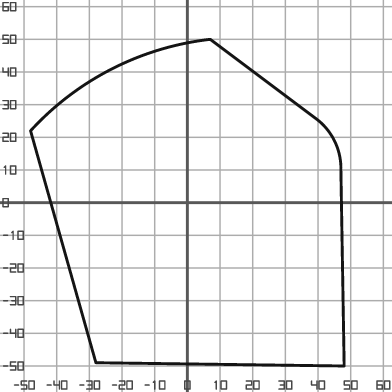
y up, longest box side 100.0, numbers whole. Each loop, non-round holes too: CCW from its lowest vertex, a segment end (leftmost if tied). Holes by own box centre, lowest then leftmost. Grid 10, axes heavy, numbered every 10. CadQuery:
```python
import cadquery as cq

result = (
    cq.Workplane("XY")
    .moveTo(48.0, -50.0)
    .lineTo(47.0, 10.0)
    .threePointArc((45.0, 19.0), (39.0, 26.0))
    .lineTo(7.0, 50.0)
    .threePointArc((-23.0, 41.0), (-48.0, 22.0))
    .lineTo(-28.0, -49.0)
    .close()
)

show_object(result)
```